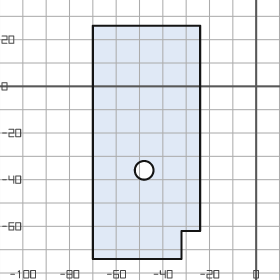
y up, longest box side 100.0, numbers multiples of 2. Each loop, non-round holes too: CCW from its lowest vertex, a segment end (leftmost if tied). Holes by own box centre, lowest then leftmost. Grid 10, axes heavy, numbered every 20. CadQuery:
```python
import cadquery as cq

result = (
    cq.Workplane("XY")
    .moveTo(-70.0, -74.0)
    .lineTo(-32.0, -74.0)
    .lineTo(-32.0, -62.0)
    .lineTo(-24.0, -62.0)
    .lineTo(-24.0, 26.0)
    .lineTo(-70.0, 26.0)
    .close()
    .moveTo(-48.0, -36.0)
    .circle(4.0)
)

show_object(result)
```